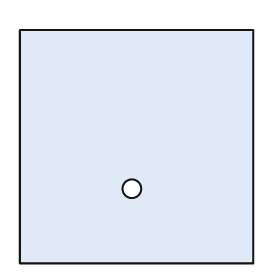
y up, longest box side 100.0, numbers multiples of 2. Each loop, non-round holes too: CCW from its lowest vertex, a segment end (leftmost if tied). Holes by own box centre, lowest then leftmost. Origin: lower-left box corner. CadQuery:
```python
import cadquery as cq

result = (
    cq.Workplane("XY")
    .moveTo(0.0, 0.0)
    .lineTo(100.0, 0.0)
    .lineTo(100.0, 100.0)
    .lineTo(0.0, 100.0)
    .close()
    .moveTo(48.0, 32.0)
    .circle(4.0)
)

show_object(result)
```